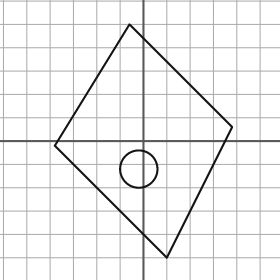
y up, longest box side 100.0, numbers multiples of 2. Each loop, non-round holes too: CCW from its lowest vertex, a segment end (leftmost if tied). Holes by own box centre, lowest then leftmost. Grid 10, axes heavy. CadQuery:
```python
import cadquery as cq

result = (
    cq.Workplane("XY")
    .moveTo(10.0, -50.0)
    .lineTo(38.0, 6.0)
    .lineTo(-6.0, 50.0)
    .lineTo(-38.0, -2.0)
    .close()
    .moveTo(-2.0, -12.0)
    .circle(8.0)
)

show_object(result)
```